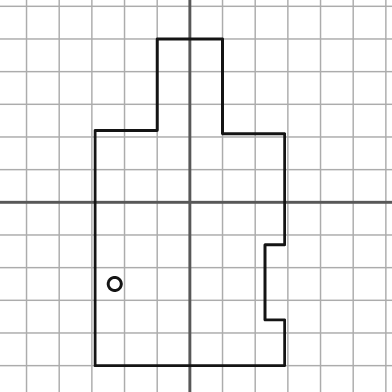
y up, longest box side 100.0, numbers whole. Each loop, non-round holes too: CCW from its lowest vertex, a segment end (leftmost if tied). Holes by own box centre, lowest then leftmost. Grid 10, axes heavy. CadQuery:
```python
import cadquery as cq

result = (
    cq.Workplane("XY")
    .moveTo(-29.0, -50.0)
    .lineTo(29.0, -50.0)
    .lineTo(29.0, -36.0)
    .lineTo(23.0, -36.0)
    .lineTo(23.0, -13.0)
    .lineTo(29.0, -13.0)
    .lineTo(29.0, 21.0)
    .lineTo(10.0, 21.0)
    .lineTo(10.0, 50.0)
    .lineTo(-10.0, 50.0)
    .lineTo(-10.0, 22.0)
    .lineTo(-29.0, 22.0)
    .close()
    .moveTo(-23.0, -25.0)
    .circle(2.0)
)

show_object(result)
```